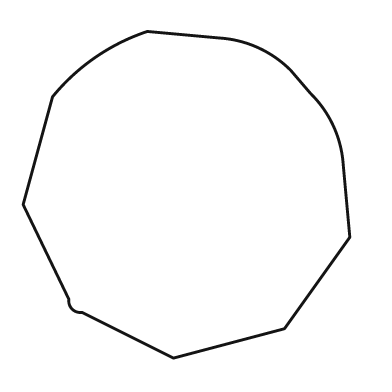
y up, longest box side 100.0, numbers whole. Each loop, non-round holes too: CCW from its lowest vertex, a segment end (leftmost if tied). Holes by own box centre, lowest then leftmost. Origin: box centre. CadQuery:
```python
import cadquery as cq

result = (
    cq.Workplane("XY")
    .moveTo(-4.0, -50.0)
    .lineTo(30.0, -41.0)
    .lineTo(50.0, -13.0)
    .lineTo(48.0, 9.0)
    .threePointArc((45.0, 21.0), (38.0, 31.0))
    .lineTo(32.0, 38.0)
    .threePointArc((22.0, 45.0), (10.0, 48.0))
    .lineTo(-12.0, 50.0)
    .threePointArc((-28.0, 42.0), (-41.0, 30.0))
    .lineTo(-50.0, -3.0)
    .lineTo(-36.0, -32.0)
    .threePointArc((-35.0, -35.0), (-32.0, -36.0))
    .close()
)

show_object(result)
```